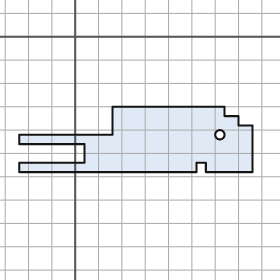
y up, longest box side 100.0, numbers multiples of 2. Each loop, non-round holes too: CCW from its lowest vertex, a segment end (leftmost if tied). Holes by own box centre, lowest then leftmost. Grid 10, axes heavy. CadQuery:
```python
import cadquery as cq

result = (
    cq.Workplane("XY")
    .moveTo(-24.0, -58.0)
    .lineTo(52.0, -58.0)
    .lineTo(52.0, -54.0)
    .lineTo(56.0, -54.0)
    .lineTo(56.0, -58.0)
    .lineTo(76.0, -58.0)
    .lineTo(76.0, -38.0)
    .lineTo(70.0, -38.0)
    .lineTo(70.0, -34.0)
    .lineTo(64.0, -34.0)
    .lineTo(64.0, -30.0)
    .lineTo(16.0, -30.0)
    .lineTo(16.0, -42.0)
    .lineTo(-24.0, -42.0)
    .lineTo(-24.0, -46.0)
    .lineTo(4.0, -46.0)
    .lineTo(4.0, -54.0)
    .lineTo(-24.0, -54.0)
    .close()
    .moveTo(62.0, -42.0)
    .circle(2.0)
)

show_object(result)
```